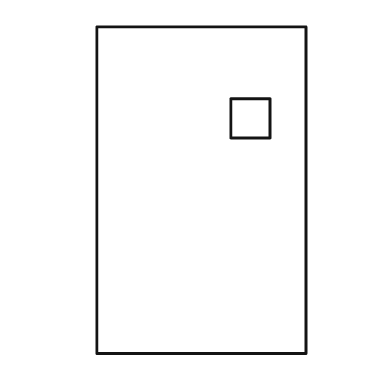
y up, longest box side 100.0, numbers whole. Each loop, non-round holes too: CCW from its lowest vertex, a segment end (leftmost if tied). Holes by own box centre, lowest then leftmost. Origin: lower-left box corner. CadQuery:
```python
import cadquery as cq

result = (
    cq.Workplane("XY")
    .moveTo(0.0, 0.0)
    .lineTo(64.0, 0.0)
    .lineTo(64.0, 100.0)
    .lineTo(0.0, 100.0)
    .close()
    .moveTo(41.0, 66.0)
    .lineTo(53.0, 66.0)
    .lineTo(53.0, 78.0)
    .lineTo(41.0, 78.0)
    .close()
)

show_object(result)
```